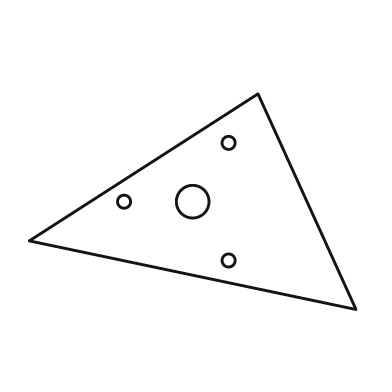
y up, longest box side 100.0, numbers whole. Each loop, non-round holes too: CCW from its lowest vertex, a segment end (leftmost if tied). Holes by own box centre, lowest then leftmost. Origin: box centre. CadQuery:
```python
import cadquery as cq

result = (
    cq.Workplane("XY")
    .moveTo(50.0, -33.0)
    .lineTo(20.0, 33.0)
    .lineTo(-50.0, -12.0)
    .close()
    .moveTo(11.0, -18.0)
    .circle(2.0)
    .moveTo(-21.0, 0.0)
    .circle(2.0)
    .moveTo(0.0, 0.0)
    .circle(5.0)
    .moveTo(11.0, 18.0)
    .circle(2.0)
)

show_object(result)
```